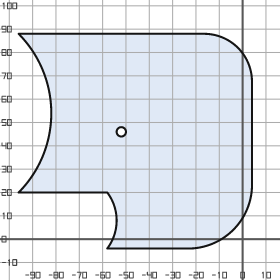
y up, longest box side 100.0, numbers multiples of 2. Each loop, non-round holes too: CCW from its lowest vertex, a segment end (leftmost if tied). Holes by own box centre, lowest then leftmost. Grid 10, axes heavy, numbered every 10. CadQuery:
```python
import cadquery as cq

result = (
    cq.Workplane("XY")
    .moveTo(-58.0, -4.0)
    .lineTo(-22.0, -4.0)
    .threePointArc((-4.0, 4.0), (4.0, 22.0))
    .lineTo(4.0, 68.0)
    .threePointArc((-2.0, 82.0), (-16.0, 88.0))
    .lineTo(-96.0, 88.0)
    .threePointArc((-82.0, 54.0), (-96.0, 20.0))
    .lineTo(-58.0, 20.0)
    .threePointArc((-54.0, 8.0), (-58.0, -4.0))
    .close()
    .moveTo(-52.0, 46.0)
    .circle(2.0)
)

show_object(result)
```